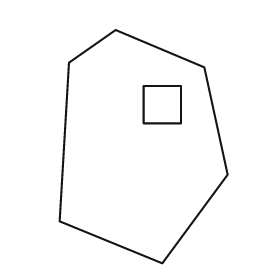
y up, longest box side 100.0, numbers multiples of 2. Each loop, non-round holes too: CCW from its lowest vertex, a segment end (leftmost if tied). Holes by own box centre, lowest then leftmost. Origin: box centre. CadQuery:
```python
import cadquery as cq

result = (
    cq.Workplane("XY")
    .moveTo(8.0, -50.0)
    .lineTo(36.0, -12.0)
    .lineTo(26.0, 34.0)
    .lineTo(-12.0, 50.0)
    .lineTo(-32.0, 36.0)
    .lineTo(-36.0, -32.0)
    .close()
    .moveTo(0.0, 10.0)
    .lineTo(16.0, 10.0)
    .lineTo(16.0, 26.0)
    .lineTo(0.0, 26.0)
    .close()
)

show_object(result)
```